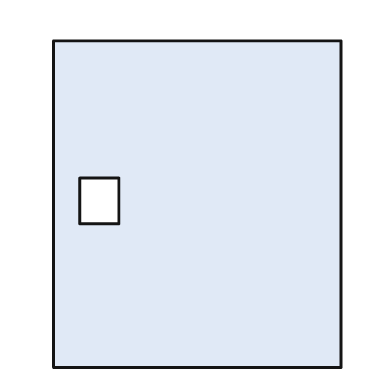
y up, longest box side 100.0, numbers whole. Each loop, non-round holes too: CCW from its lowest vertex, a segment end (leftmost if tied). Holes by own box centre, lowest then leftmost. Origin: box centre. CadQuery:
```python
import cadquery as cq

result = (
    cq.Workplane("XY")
    .moveTo(-44.0, -50.0)
    .lineTo(44.0, -50.0)
    .lineTo(44.0, 50.0)
    .lineTo(-44.0, 50.0)
    .close()
    .moveTo(-36.0, -6.0)
    .lineTo(-24.0, -6.0)
    .lineTo(-24.0, 8.0)
    .lineTo(-36.0, 8.0)
    .close()
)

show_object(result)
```